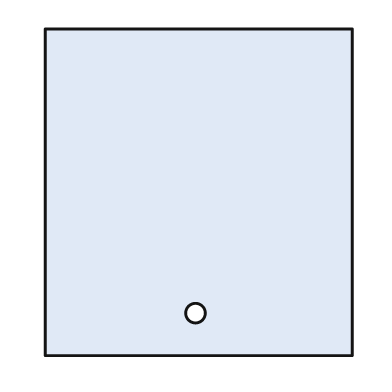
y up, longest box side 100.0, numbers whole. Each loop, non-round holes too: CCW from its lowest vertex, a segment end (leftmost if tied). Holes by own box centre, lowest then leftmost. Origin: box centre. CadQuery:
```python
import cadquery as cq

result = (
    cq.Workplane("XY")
    .moveTo(-47.0, -50.0)
    .lineTo(47.0, -50.0)
    .lineTo(47.0, 50.0)
    .lineTo(-47.0, 50.0)
    .close()
    .moveTo(-1.0, -37.0)
    .circle(3.0)
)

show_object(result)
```